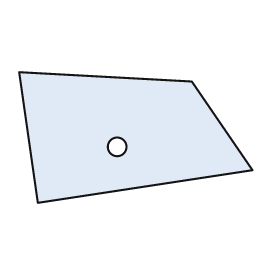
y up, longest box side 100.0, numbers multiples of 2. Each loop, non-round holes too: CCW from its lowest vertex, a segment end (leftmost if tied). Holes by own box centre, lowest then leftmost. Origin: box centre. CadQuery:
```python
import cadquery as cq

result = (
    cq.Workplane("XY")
    .moveTo(-42.0, -28.0)
    .lineTo(50.0, -14.0)
    .lineTo(24.0, 24.0)
    .lineTo(-50.0, 28.0)
    .close()
    .moveTo(-8.0, -4.0)
    .circle(4.0)
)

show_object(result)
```